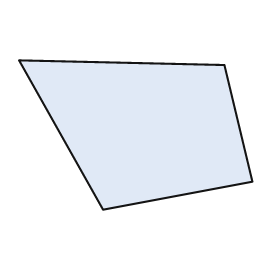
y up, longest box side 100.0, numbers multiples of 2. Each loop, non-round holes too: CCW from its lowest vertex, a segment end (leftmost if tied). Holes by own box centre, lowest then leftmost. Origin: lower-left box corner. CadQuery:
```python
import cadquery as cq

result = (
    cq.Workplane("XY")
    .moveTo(36.0, 0.0)
    .lineTo(100.0, 12.0)
    .lineTo(88.0, 62.0)
    .lineTo(0.0, 64.0)
    .close()
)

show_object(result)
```